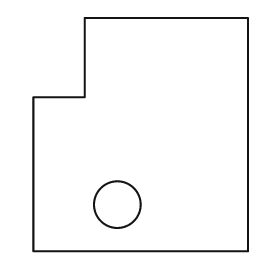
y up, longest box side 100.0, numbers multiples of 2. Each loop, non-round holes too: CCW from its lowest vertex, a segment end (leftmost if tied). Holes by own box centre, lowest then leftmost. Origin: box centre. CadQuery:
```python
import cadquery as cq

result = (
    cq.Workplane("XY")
    .moveTo(-46.0, -50.0)
    .lineTo(46.0, -50.0)
    .lineTo(46.0, 50.0)
    .lineTo(-24.0, 50.0)
    .lineTo(-24.0, 16.0)
    .lineTo(-46.0, 16.0)
    .close()
    .moveTo(-10.0, -30.0)
    .circle(10.0)
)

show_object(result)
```